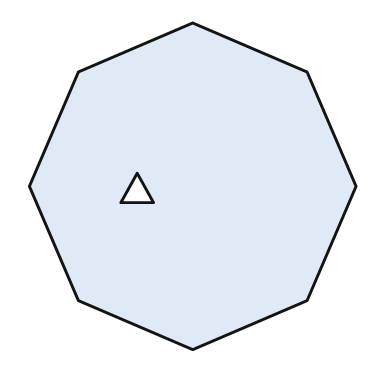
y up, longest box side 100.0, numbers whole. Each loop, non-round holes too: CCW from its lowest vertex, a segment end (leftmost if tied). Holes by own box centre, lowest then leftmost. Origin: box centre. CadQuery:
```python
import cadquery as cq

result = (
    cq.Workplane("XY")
    .moveTo(0.0, -50.0)
    .lineTo(35.0, -35.0)
    .lineTo(50.0, 0.0)
    .lineTo(35.0, 35.0)
    .lineTo(0.0, 50.0)
    .lineTo(-35.0, 35.0)
    .lineTo(-50.0, 0.0)
    .lineTo(-35.0, -35.0)
    .close()
    .moveTo(-22.0, -5.0)
    .lineTo(-12.0, -5.0)
    .lineTo(-17.0, 4.0)
    .close()
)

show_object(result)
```